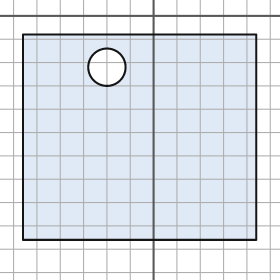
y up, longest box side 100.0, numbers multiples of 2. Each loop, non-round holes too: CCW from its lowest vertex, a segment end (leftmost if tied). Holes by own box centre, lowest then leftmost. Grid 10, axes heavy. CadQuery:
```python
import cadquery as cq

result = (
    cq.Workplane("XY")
    .moveTo(-56.0, -96.0)
    .lineTo(44.0, -96.0)
    .lineTo(44.0, -8.0)
    .lineTo(-56.0, -8.0)
    .close()
    .moveTo(-20.0, -22.0)
    .circle(8.0)
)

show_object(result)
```